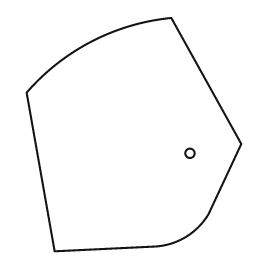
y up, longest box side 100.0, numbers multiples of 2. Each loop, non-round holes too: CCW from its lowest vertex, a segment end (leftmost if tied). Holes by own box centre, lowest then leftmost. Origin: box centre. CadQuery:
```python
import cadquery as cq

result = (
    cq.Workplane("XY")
    .moveTo(-34.0, -50.0)
    .lineTo(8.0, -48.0)
    .threePointArc((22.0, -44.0), (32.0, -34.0))
    .lineTo(46.0, -4.0)
    .lineTo(16.0, 50.0)
    .threePointArc((-18.0, 40.0), (-46.0, 18.0))
    .close()
    .moveTo(24.0, -8.0)
    .circle(2.0)
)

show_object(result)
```